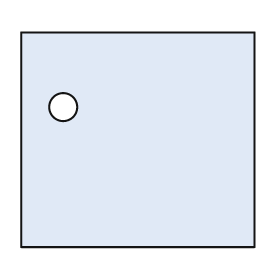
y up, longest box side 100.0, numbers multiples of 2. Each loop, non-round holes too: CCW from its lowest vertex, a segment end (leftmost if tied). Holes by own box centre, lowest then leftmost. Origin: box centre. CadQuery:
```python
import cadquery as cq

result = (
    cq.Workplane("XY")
    .moveTo(-50.0, -46.0)
    .lineTo(50.0, -46.0)
    .lineTo(50.0, 46.0)
    .lineTo(-50.0, 46.0)
    .close()
    .moveTo(-32.0, 14.0)
    .circle(6.0)
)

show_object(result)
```